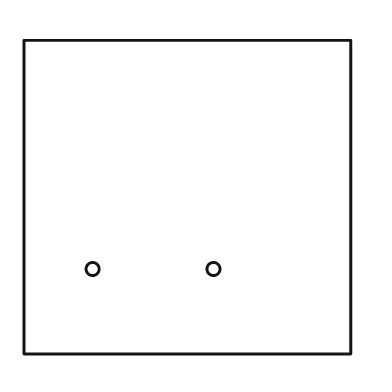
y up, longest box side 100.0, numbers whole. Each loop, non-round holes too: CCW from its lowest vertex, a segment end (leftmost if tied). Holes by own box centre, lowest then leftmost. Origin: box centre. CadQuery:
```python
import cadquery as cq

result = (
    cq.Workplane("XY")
    .moveTo(-50.0, -48.0)
    .lineTo(50.0, -48.0)
    .lineTo(50.0, 48.0)
    .lineTo(-50.0, 48.0)
    .close()
    .moveTo(-29.0, -22.0)
    .circle(2.0)
    .moveTo(8.0, -22.0)
    .circle(2.0)
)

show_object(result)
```